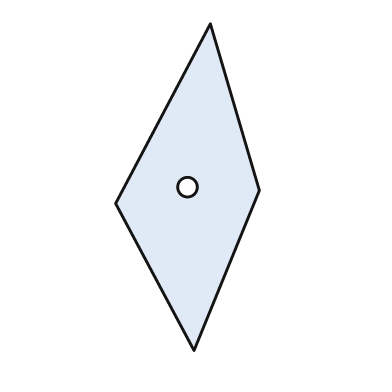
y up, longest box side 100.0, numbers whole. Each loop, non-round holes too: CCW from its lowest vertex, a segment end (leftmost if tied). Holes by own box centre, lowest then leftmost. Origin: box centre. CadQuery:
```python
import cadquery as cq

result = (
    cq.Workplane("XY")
    .moveTo(2.0, -50.0)
    .lineTo(22.0, -1.0)
    .lineTo(7.0, 50.0)
    .lineTo(-22.0, -5.0)
    .close()
    .moveTo(0.0, 0.0)
    .circle(3.0)
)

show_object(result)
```